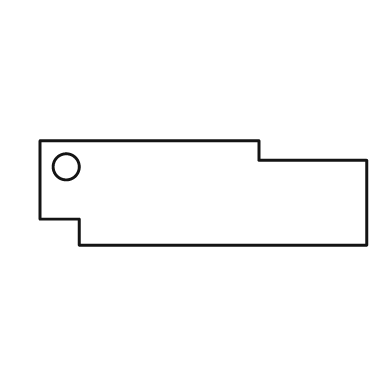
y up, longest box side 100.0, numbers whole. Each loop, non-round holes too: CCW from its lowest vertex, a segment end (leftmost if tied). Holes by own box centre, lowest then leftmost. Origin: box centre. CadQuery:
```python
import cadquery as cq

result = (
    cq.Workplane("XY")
    .moveTo(-38.0, -16.0)
    .lineTo(50.0, -16.0)
    .lineTo(50.0, 10.0)
    .lineTo(17.0, 10.0)
    .lineTo(17.0, 16.0)
    .lineTo(-50.0, 16.0)
    .lineTo(-50.0, -8.0)
    .lineTo(-38.0, -8.0)
    .close()
    .moveTo(-42.0, 8.0)
    .circle(4.0)
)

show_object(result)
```